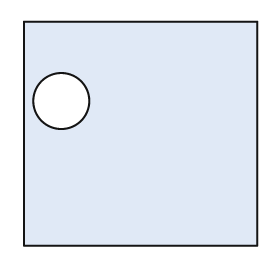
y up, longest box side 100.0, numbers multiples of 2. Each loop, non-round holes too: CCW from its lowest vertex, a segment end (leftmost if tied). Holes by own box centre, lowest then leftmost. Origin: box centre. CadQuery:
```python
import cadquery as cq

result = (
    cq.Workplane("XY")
    .moveTo(-50.0, -48.0)
    .lineTo(50.0, -48.0)
    .lineTo(50.0, 48.0)
    .lineTo(-50.0, 48.0)
    .close()
    .moveTo(-34.0, 14.0)
    .circle(12.0)
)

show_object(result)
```